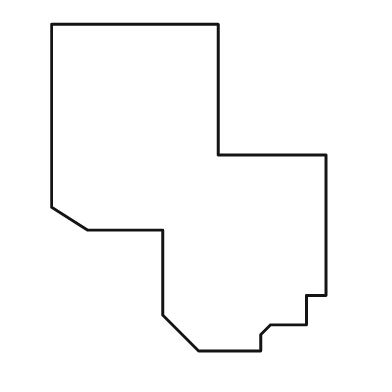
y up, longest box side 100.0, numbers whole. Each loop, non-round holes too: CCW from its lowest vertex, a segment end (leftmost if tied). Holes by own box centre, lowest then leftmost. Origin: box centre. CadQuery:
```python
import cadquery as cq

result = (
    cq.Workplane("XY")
    .moveTo(3.0, -50.0)
    .lineTo(22.0, -50.0)
    .lineTo(22.0, -45.0)
    .lineTo(25.0, -42.0)
    .lineTo(36.0, -42.0)
    .lineTo(36.0, -33.0)
    .lineTo(42.0, -33.0)
    .lineTo(42.0, 10.0)
    .lineTo(9.0, 10.0)
    .lineTo(9.0, 50.0)
    .lineTo(-42.0, 50.0)
    .lineTo(-42.0, -6.0)
    .lineTo(-31.0, -13.0)
    .lineTo(-8.0, -13.0)
    .lineTo(-8.0, -39.0)
    .close()
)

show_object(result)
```